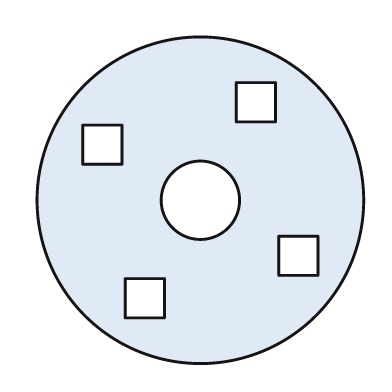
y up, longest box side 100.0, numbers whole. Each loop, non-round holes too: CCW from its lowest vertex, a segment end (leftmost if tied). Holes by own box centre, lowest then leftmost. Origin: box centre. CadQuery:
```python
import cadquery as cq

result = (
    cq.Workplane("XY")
    .moveTo(0.0, 0.0)
    .circle(50.0)
    .moveTo(-23.0, -36.0)
    .lineTo(-11.0, -36.0)
    .lineTo(-11.0, -24.0)
    .lineTo(-23.0, -24.0)
    .close()
    .moveTo(24.0, -23.0)
    .lineTo(36.0, -23.0)
    .lineTo(36.0, -11.0)
    .lineTo(24.0, -11.0)
    .close()
    .moveTo(0.0, 0.0)
    .circle(12.0)
    .moveTo(-36.0, 11.0)
    .lineTo(-24.0, 11.0)
    .lineTo(-24.0, 23.0)
    .lineTo(-36.0, 23.0)
    .close()
    .moveTo(11.0, 24.0)
    .lineTo(23.0, 24.0)
    .lineTo(23.0, 36.0)
    .lineTo(11.0, 36.0)
    .close()
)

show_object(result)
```